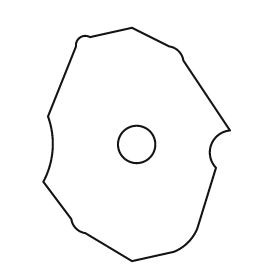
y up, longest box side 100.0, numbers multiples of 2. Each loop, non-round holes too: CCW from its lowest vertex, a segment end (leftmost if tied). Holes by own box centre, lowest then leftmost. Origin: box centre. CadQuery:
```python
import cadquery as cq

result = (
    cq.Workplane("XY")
    .moveTo(-2.0, -50.0)
    .lineTo(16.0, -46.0)
    .threePointArc((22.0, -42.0), (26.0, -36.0))
    .lineTo(34.0, -10.0)
    .threePointArc((32.0, 0.0), (40.0, 6.0))
    .lineTo(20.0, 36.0)
    .threePointArc((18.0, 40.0), (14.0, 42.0))
    .lineTo(-2.0, 50.0)
    .lineTo(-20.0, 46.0)
    .threePointArc((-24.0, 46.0), (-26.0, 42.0))
    .lineTo(-38.0, 12.0)
    .threePointArc((-36.0, -2.0), (-40.0, -16.0))
    .lineTo(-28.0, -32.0)
    .threePointArc((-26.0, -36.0), (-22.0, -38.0))
    .close()
    .moveTo(0.0, 0.0)
    .circle(8.0)
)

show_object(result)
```